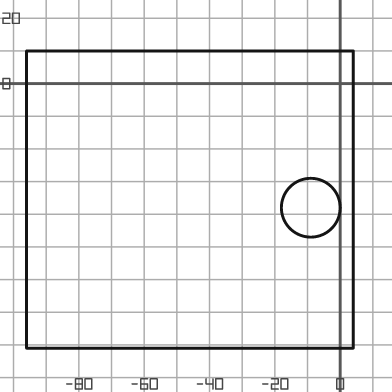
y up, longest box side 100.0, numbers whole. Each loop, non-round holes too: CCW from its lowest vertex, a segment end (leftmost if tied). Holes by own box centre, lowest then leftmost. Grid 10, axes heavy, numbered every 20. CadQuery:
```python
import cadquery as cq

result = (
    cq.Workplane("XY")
    .moveTo(-96.0, -81.0)
    .lineTo(4.0, -81.0)
    .lineTo(4.0, 10.0)
    .lineTo(-96.0, 10.0)
    .close()
    .moveTo(-9.0, -38.0)
    .circle(9.0)
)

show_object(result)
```